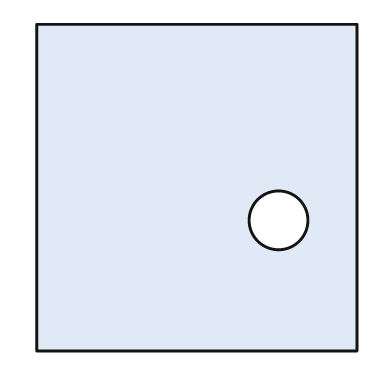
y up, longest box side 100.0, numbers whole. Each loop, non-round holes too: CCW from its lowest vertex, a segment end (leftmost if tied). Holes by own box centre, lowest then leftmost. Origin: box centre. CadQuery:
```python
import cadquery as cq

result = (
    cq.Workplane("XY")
    .moveTo(-49.0, -50.0)
    .lineTo(49.0, -50.0)
    .lineTo(49.0, 50.0)
    .lineTo(-49.0, 50.0)
    .close()
    .moveTo(25.0, -10.0)
    .circle(9.0)
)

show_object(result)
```